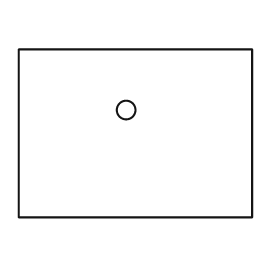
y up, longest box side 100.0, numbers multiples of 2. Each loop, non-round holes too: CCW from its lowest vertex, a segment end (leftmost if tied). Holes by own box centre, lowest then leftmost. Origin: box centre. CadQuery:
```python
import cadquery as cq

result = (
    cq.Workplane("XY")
    .moveTo(-50.0, -36.0)
    .lineTo(50.0, -36.0)
    .lineTo(50.0, 36.0)
    .lineTo(-50.0, 36.0)
    .close()
    .moveTo(-4.0, 10.0)
    .circle(4.0)
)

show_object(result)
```